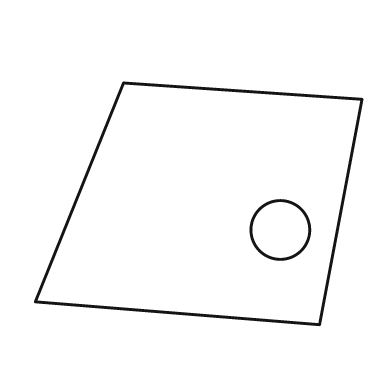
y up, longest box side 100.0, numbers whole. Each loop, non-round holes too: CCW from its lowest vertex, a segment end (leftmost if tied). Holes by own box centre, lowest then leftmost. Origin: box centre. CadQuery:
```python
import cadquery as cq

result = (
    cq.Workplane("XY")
    .moveTo(37.0, -37.0)
    .lineTo(50.0, 32.0)
    .lineTo(-23.0, 37.0)
    .lineTo(-50.0, -30.0)
    .close()
    .moveTo(25.0, -8.0)
    .circle(9.0)
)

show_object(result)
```